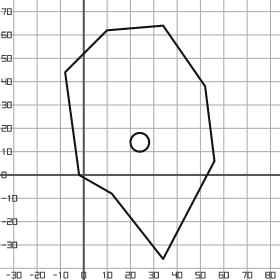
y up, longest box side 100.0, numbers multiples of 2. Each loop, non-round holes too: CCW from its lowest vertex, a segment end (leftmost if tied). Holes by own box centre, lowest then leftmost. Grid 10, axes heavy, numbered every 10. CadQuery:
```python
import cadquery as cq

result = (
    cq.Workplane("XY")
    .moveTo(34.0, -36.0)
    .lineTo(56.0, 6.0)
    .lineTo(52.0, 38.0)
    .lineTo(34.0, 64.0)
    .lineTo(10.0, 62.0)
    .lineTo(-8.0, 44.0)
    .lineTo(-2.0, 0.0)
    .lineTo(12.0, -8.0)
    .close()
    .moveTo(24.0, 14.0)
    .circle(4.0)
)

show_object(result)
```